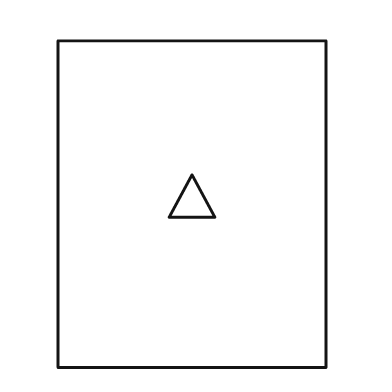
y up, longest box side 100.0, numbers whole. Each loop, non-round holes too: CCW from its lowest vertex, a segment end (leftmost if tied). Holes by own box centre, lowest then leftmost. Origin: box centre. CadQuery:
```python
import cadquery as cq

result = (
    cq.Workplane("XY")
    .moveTo(-41.0, -50.0)
    .lineTo(41.0, -50.0)
    .lineTo(41.0, 50.0)
    .lineTo(-41.0, 50.0)
    .close()
    .moveTo(-7.0, -4.0)
    .lineTo(7.0, -4.0)
    .lineTo(0.0, 9.0)
    .close()
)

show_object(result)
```